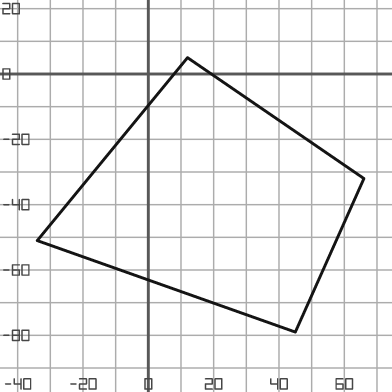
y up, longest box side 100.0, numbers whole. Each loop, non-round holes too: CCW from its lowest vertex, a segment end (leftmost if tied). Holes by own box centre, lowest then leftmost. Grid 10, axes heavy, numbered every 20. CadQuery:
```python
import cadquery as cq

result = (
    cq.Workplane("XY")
    .moveTo(45.0, -79.0)
    .lineTo(66.0, -32.0)
    .lineTo(12.0, 5.0)
    .lineTo(-34.0, -51.0)
    .close()
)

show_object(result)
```